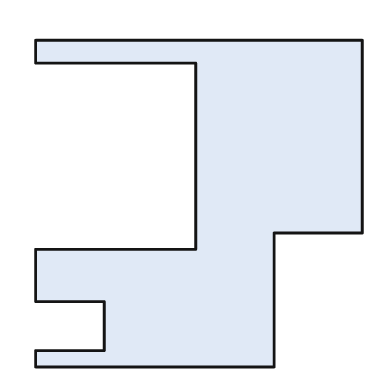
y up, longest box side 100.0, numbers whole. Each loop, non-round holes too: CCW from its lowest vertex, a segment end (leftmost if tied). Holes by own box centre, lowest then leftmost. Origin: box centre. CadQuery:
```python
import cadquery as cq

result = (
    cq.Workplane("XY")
    .moveTo(-50.0, -50.0)
    .lineTo(23.0, -50.0)
    .lineTo(23.0, -9.0)
    .lineTo(50.0, -9.0)
    .lineTo(50.0, 50.0)
    .lineTo(-50.0, 50.0)
    .lineTo(-50.0, 43.0)
    .lineTo(-1.0, 43.0)
    .lineTo(-1.0, -14.0)
    .lineTo(-50.0, -14.0)
    .lineTo(-50.0, -30.0)
    .lineTo(-29.0, -30.0)
    .lineTo(-29.0, -45.0)
    .lineTo(-50.0, -45.0)
    .close()
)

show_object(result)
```